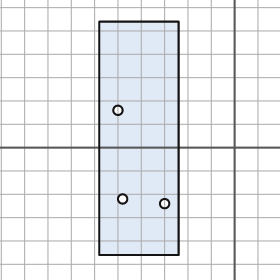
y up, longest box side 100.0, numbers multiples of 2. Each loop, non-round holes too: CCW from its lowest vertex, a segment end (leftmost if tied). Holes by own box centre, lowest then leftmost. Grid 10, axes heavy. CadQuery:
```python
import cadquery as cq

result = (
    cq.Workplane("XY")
    .moveTo(-58.0, -46.0)
    .lineTo(-24.0, -46.0)
    .lineTo(-24.0, 54.0)
    .lineTo(-58.0, 54.0)
    .close()
    .moveTo(-30.0, -24.0)
    .circle(2.0)
    .moveTo(-48.0, -22.0)
    .circle(2.0)
    .moveTo(-50.0, 16.0)
    .circle(2.0)
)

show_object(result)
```